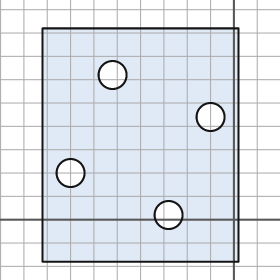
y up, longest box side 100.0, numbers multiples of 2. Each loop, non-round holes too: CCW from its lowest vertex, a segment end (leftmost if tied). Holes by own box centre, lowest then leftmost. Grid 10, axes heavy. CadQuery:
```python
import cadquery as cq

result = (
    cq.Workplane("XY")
    .moveTo(-82.0, -18.0)
    .lineTo(2.0, -18.0)
    .lineTo(2.0, 82.0)
    .lineTo(-82.0, 82.0)
    .close()
    .moveTo(-28.0, 2.0)
    .circle(6.0)
    .moveTo(-70.0, 20.0)
    .circle(6.0)
    .moveTo(-10.0, 44.0)
    .circle(6.0)
    .moveTo(-52.0, 62.0)
    .circle(6.0)
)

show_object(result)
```